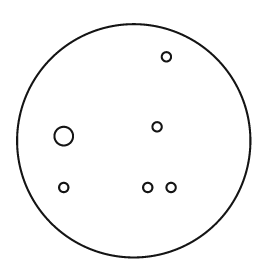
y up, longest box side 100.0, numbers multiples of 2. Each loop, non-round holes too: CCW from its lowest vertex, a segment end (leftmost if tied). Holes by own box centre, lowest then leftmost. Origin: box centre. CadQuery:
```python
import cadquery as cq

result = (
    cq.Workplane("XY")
    .moveTo(0.0, 0.0)
    .circle(50.0)
    .moveTo(-30.0, -20.0)
    .circle(2.0)
    .moveTo(6.0, -20.0)
    .circle(2.0)
    .moveTo(16.0, -20.0)
    .circle(2.0)
    .moveTo(-30.0, 2.0)
    .circle(4.0)
    .moveTo(10.0, 6.0)
    .circle(2.0)
    .moveTo(14.0, 36.0)
    .circle(2.0)
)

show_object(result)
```